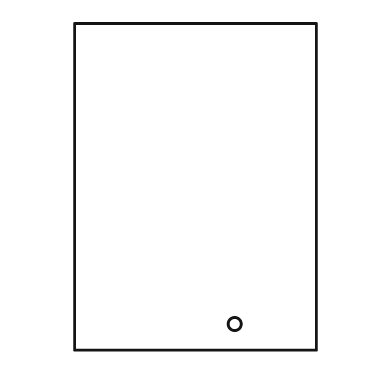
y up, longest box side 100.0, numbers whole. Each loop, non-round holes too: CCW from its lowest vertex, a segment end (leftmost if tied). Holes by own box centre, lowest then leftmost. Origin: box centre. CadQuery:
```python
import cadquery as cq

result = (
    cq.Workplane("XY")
    .moveTo(-37.0, -50.0)
    .lineTo(37.0, -50.0)
    .lineTo(37.0, 50.0)
    .lineTo(-37.0, 50.0)
    .close()
    .moveTo(12.0, -42.0)
    .circle(2.0)
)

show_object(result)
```